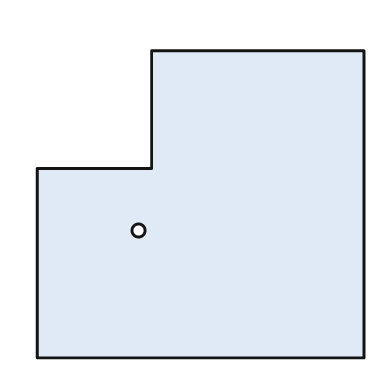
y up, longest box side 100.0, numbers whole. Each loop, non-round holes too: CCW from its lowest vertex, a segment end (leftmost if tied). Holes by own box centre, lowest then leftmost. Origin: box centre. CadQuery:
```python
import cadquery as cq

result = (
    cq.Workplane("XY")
    .moveTo(-50.0, -47.0)
    .lineTo(50.0, -47.0)
    .lineTo(50.0, 47.0)
    .lineTo(-15.0, 47.0)
    .lineTo(-15.0, 11.0)
    .lineTo(-50.0, 11.0)
    .close()
    .moveTo(-19.0, -8.0)
    .circle(2.0)
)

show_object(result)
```